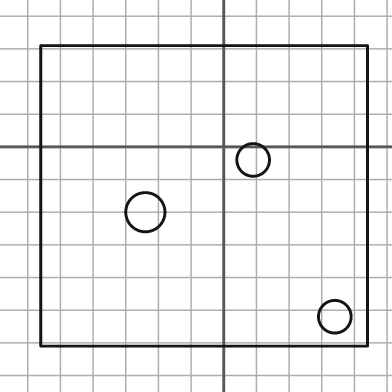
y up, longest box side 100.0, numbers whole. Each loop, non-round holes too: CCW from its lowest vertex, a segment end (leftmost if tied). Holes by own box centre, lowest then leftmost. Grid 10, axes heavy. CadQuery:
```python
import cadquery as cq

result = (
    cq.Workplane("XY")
    .moveTo(-56.0, -61.0)
    .lineTo(44.0, -61.0)
    .lineTo(44.0, 31.0)
    .lineTo(-56.0, 31.0)
    .close()
    .moveTo(34.0, -52.0)
    .circle(5.0)
    .moveTo(-24.0, -20.0)
    .circle(6.0)
    .moveTo(9.0, -4.0)
    .circle(5.0)
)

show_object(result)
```